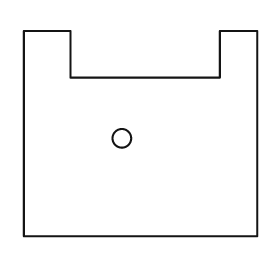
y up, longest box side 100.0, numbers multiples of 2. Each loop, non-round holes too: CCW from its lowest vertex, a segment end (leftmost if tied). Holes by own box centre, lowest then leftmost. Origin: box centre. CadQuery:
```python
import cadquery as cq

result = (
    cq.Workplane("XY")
    .moveTo(-50.0, -44.0)
    .lineTo(50.0, -44.0)
    .lineTo(50.0, 44.0)
    .lineTo(34.0, 44.0)
    .lineTo(34.0, 24.0)
    .lineTo(-30.0, 24.0)
    .lineTo(-30.0, 44.0)
    .lineTo(-50.0, 44.0)
    .close()
    .moveTo(-8.0, -2.0)
    .circle(4.0)
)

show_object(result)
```